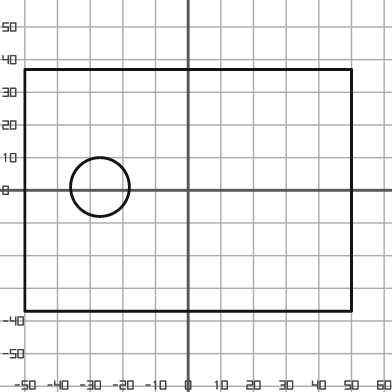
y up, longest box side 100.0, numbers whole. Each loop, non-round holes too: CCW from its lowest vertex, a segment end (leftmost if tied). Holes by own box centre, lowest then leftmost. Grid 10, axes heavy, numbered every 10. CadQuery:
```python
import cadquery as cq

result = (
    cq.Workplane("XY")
    .moveTo(-50.0, -37.0)
    .lineTo(50.0, -37.0)
    .lineTo(50.0, 37.0)
    .lineTo(-50.0, 37.0)
    .close()
    .moveTo(-27.0, 1.0)
    .circle(9.0)
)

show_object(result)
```